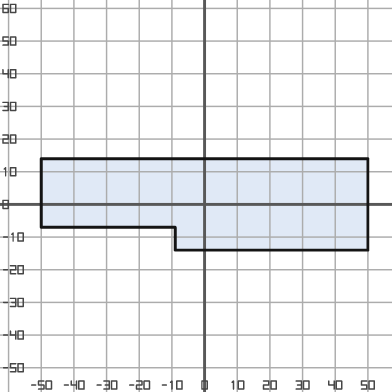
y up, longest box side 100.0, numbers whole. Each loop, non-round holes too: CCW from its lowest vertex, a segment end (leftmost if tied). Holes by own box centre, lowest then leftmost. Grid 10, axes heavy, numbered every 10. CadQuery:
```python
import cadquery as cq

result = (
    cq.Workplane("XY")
    .moveTo(-9.0, -14.0)
    .lineTo(50.0, -14.0)
    .lineTo(50.0, 14.0)
    .lineTo(-50.0, 14.0)
    .lineTo(-50.0, -7.0)
    .lineTo(-9.0, -7.0)
    .close()
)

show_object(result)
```